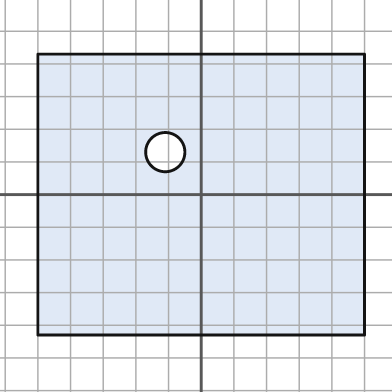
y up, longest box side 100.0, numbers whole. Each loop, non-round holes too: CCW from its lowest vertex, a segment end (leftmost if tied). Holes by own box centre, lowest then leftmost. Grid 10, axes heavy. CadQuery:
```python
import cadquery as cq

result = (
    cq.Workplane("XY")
    .moveTo(-50.0, -43.0)
    .lineTo(50.0, -43.0)
    .lineTo(50.0, 43.0)
    .lineTo(-50.0, 43.0)
    .close()
    .moveTo(-11.0, 13.0)
    .circle(6.0)
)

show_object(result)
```